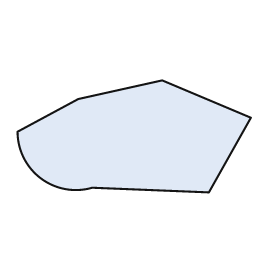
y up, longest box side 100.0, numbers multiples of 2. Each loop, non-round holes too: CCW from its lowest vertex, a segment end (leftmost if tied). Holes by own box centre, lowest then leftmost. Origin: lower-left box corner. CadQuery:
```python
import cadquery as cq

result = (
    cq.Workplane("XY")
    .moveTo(82.0, 0.0)
    .lineTo(100.0, 32.0)
    .lineTo(62.0, 48.0)
    .lineTo(26.0, 40.0)
    .lineTo(0.0, 26.0)
    .threePointArc((10.0, 6.0), (32.0, 2.0))
    .close()
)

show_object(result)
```